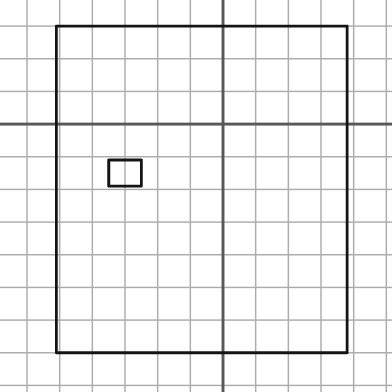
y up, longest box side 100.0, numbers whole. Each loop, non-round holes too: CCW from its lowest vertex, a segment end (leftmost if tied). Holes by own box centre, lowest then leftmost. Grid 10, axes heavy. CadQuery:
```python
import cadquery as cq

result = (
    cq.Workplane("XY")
    .moveTo(-51.0, -70.0)
    .lineTo(38.0, -70.0)
    .lineTo(38.0, 30.0)
    .lineTo(-51.0, 30.0)
    .close()
    .moveTo(-35.0, -19.0)
    .lineTo(-25.0, -19.0)
    .lineTo(-25.0, -11.0)
    .lineTo(-35.0, -11.0)
    .close()
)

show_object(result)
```